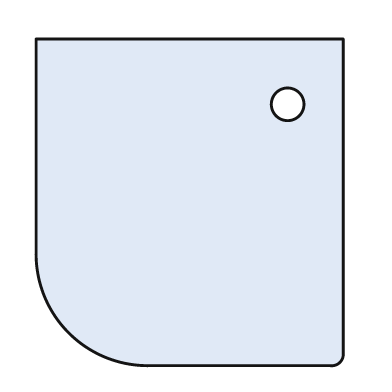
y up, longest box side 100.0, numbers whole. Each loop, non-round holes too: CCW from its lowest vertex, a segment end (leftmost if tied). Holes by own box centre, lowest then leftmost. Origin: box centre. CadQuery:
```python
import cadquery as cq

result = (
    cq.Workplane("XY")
    .moveTo(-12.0, -50.0)
    .lineTo(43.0, -50.0)
    .threePointArc((46.0, -49.0), (47.0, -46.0))
    .lineTo(47.0, 50.0)
    .lineTo(-47.0, 50.0)
    .lineTo(-47.0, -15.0)
    .threePointArc((-37.0, -40.0), (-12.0, -50.0))
    .close()
    .moveTo(30.0, 30.0)
    .circle(5.0)
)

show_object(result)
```